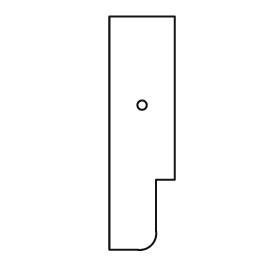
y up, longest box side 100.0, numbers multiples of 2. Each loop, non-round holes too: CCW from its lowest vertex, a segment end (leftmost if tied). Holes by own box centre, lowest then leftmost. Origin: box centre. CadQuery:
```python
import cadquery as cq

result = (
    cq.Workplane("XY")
    .moveTo(-14.0, -50.0)
    .lineTo(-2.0, -50.0)
    .threePointArc((4.0, -48.0), (6.0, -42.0))
    .lineTo(6.0, -20.0)
    .lineTo(14.0, -20.0)
    .lineTo(14.0, 50.0)
    .lineTo(-14.0, 50.0)
    .close()
    .moveTo(0.0, 12.0)
    .circle(2.0)
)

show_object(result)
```